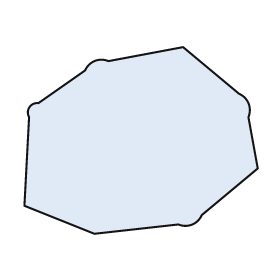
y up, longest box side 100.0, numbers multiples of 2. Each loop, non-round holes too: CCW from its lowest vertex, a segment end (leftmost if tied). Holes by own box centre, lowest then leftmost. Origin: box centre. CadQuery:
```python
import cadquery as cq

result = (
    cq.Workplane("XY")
    .moveTo(-20.0, -40.0)
    .lineTo(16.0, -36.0)
    .threePointArc((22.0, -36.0), (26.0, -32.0))
    .lineTo(50.0, -12.0)
    .lineTo(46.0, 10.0)
    .threePointArc((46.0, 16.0), (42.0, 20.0))
    .lineTo(18.0, 40.0)
    .lineTo(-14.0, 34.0)
    .threePointArc((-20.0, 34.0), (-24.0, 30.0))
    .lineTo(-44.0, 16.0)
    .threePointArc((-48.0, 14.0), (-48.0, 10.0))
    .lineTo(-50.0, -28.0)
    .close()
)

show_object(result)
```